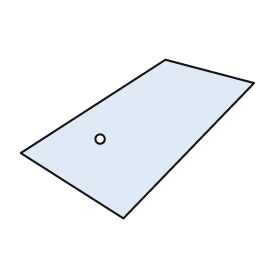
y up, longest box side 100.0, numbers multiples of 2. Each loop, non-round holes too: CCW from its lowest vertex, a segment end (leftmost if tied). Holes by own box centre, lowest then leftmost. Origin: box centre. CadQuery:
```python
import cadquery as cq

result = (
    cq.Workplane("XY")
    .moveTo(-6.0, -34.0)
    .lineTo(50.0, 24.0)
    .lineTo(12.0, 34.0)
    .lineTo(-50.0, -6.0)
    .close()
    .moveTo(-16.0, 0.0)
    .circle(2.0)
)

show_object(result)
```